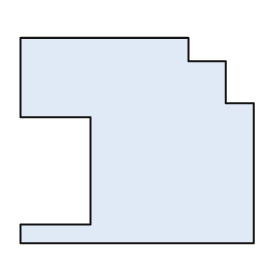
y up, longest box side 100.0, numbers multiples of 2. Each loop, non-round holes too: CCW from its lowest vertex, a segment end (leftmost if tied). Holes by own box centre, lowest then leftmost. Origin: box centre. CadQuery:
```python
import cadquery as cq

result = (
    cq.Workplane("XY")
    .moveTo(-50.0, -44.0)
    .lineTo(50.0, -44.0)
    .lineTo(50.0, 16.0)
    .lineTo(38.0, 16.0)
    .lineTo(38.0, 34.0)
    .lineTo(22.0, 34.0)
    .lineTo(22.0, 44.0)
    .lineTo(-50.0, 44.0)
    .lineTo(-50.0, 10.0)
    .lineTo(-20.0, 10.0)
    .lineTo(-20.0, -36.0)
    .lineTo(-50.0, -36.0)
    .close()
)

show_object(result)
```